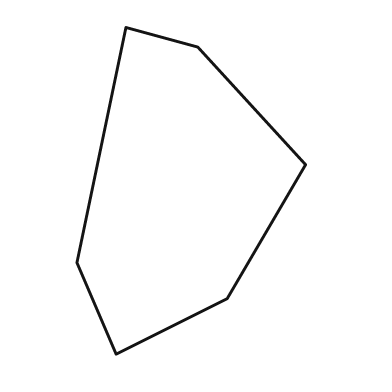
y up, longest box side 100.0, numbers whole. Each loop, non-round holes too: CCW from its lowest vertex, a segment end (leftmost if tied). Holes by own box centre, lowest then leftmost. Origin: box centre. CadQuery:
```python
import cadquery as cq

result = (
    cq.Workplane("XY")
    .moveTo(-23.0, -50.0)
    .lineTo(11.0, -33.0)
    .lineTo(35.0, 8.0)
    .lineTo(2.0, 44.0)
    .lineTo(-20.0, 50.0)
    .lineTo(-35.0, -22.0)
    .close()
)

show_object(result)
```